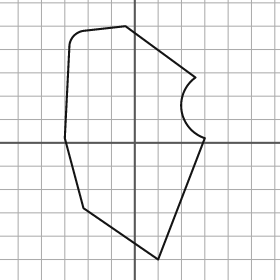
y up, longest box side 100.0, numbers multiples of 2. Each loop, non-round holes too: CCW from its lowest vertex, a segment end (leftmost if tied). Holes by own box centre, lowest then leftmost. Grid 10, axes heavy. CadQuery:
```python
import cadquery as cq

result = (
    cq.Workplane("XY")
    .moveTo(10.0, -50.0)
    .lineTo(30.0, 2.0)
    .threePointArc((20.0, 14.0), (26.0, 28.0))
    .lineTo(-4.0, 50.0)
    .lineTo(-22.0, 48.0)
    .threePointArc((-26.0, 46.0), (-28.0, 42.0))
    .lineTo(-30.0, 2.0)
    .lineTo(-22.0, -28.0)
    .close()
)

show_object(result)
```